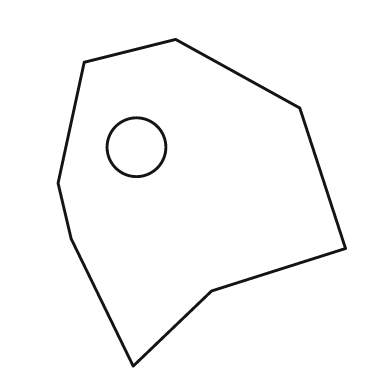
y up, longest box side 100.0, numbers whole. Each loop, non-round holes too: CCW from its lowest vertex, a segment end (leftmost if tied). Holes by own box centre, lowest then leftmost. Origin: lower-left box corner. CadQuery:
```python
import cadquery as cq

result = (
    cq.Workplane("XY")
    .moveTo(23.0, 0.0)
    .lineTo(47.0, 23.0)
    .lineTo(88.0, 36.0)
    .lineTo(74.0, 79.0)
    .lineTo(36.0, 100.0)
    .lineTo(8.0, 93.0)
    .lineTo(0.0, 56.0)
    .lineTo(4.0, 39.0)
    .close()
    .moveTo(24.0, 67.0)
    .circle(9.0)
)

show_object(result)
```